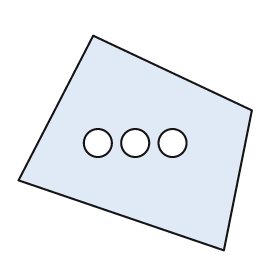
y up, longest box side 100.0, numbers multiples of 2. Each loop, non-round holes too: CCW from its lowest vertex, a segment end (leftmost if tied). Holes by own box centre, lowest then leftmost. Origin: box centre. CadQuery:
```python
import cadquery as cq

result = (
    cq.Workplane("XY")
    .moveTo(38.0, -46.0)
    .lineTo(50.0, 14.0)
    .lineTo(-18.0, 46.0)
    .lineTo(-50.0, -16.0)
    .close()
    .moveTo(-16.0, 0.0)
    .circle(6.0)
    .moveTo(0.0, 0.0)
    .circle(6.0)
    .moveTo(16.0, 0.0)
    .circle(6.0)
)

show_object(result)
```